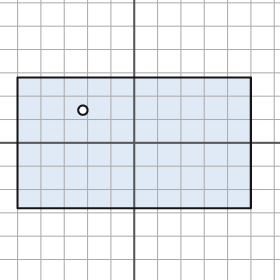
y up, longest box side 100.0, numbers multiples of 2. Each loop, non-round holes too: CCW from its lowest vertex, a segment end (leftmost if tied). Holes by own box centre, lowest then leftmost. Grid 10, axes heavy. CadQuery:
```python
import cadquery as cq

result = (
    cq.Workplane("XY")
    .moveTo(-50.0, -28.0)
    .lineTo(50.0, -28.0)
    .lineTo(50.0, 28.0)
    .lineTo(-50.0, 28.0)
    .close()
    .moveTo(-22.0, 14.0)
    .circle(2.0)
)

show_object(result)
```